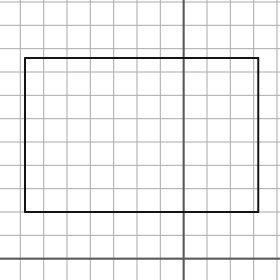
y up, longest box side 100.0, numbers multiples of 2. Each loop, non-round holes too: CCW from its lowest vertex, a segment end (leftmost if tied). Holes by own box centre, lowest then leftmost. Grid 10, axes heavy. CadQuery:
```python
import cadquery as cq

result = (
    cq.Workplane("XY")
    .moveTo(-68.0, 20.0)
    .lineTo(32.0, 20.0)
    .lineTo(32.0, 86.0)
    .lineTo(-68.0, 86.0)
    .close()
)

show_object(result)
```